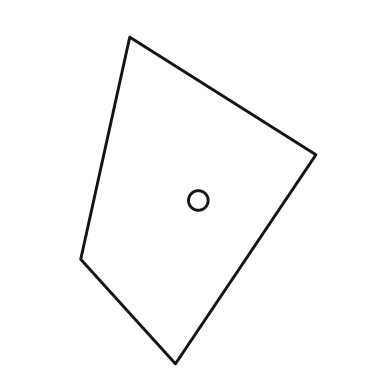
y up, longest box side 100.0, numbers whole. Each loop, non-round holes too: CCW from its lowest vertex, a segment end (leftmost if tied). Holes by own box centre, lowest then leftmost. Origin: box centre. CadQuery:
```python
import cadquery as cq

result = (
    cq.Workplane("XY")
    .moveTo(-7.0, -50.0)
    .lineTo(36.0, 14.0)
    .lineTo(-21.0, 50.0)
    .lineTo(-36.0, -18.0)
    .close()
    .moveTo(0.0, 0.0)
    .circle(3.0)
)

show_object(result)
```